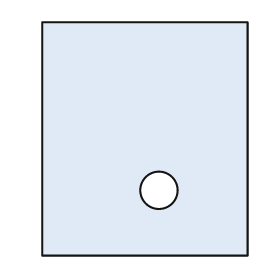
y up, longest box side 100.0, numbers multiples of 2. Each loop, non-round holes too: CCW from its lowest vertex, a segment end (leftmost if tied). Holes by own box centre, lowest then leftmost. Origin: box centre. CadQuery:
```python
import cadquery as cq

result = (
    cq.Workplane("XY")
    .moveTo(-44.0, -50.0)
    .lineTo(44.0, -50.0)
    .lineTo(44.0, 50.0)
    .lineTo(-44.0, 50.0)
    .close()
    .moveTo(6.0, -22.0)
    .circle(8.0)
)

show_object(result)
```